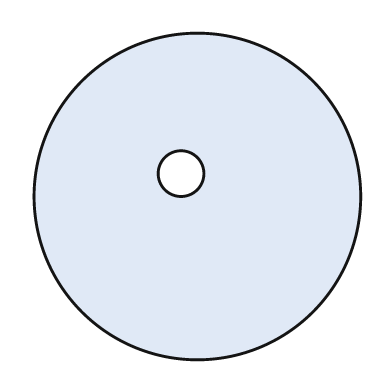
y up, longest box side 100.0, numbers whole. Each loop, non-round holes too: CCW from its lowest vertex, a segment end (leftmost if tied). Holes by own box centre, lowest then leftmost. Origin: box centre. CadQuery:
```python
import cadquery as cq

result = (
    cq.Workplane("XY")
    .moveTo(0.0, 0.0)
    .circle(50.0)
    .moveTo(-5.0, 7.0)
    .circle(7.0)
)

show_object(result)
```